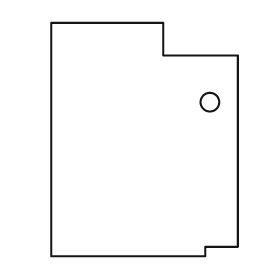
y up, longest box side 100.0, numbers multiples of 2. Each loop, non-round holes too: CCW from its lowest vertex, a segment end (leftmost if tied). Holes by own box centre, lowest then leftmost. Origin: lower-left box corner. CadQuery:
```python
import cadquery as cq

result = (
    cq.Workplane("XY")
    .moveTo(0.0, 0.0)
    .lineTo(66.0, 0.0)
    .lineTo(66.0, 4.0)
    .lineTo(80.0, 4.0)
    .lineTo(80.0, 86.0)
    .lineTo(48.0, 86.0)
    .lineTo(48.0, 100.0)
    .lineTo(0.0, 100.0)
    .close()
    .moveTo(68.0, 66.0)
    .circle(4.0)
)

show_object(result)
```